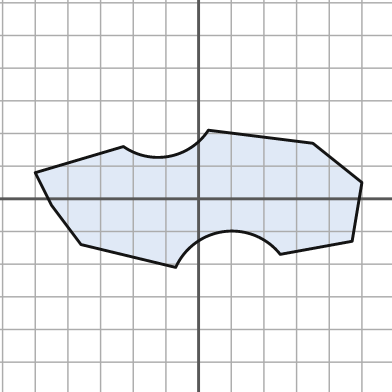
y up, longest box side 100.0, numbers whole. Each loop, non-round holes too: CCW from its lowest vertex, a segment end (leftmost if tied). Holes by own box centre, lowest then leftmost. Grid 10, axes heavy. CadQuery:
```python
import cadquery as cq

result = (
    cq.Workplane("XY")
    .moveTo(-7.0, -21.0)
    .threePointArc((8.0, -10.0), (25.0, -17.0))
    .lineTo(47.0, -13.0)
    .lineTo(50.0, 5.0)
    .lineTo(35.0, 17.0)
    .lineTo(3.0, 21.0)
    .threePointArc((-9.0, 13.0), (-23.0, 16.0))
    .lineTo(-50.0, 8.0)
    .lineTo(-45.0, -2.0)
    .lineTo(-36.0, -14.0)
    .close()
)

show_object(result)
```